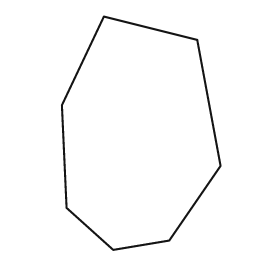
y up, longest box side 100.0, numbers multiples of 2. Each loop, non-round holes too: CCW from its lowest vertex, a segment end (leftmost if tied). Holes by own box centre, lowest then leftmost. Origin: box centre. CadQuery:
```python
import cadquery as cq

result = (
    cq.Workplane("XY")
    .moveTo(-12.0, -50.0)
    .lineTo(12.0, -46.0)
    .lineTo(34.0, -14.0)
    .lineTo(24.0, 40.0)
    .lineTo(-16.0, 50.0)
    .lineTo(-34.0, 12.0)
    .lineTo(-32.0, -32.0)
    .close()
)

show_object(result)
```